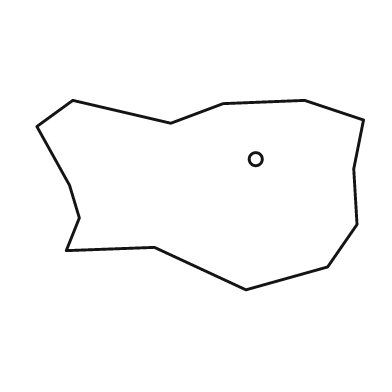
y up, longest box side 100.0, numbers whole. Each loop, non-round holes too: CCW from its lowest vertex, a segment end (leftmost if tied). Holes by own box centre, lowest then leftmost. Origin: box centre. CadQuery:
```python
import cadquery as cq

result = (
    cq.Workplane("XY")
    .moveTo(14.0, -29.0)
    .lineTo(39.0, -22.0)
    .lineTo(48.0, -9.0)
    .lineTo(47.0, 8.0)
    .lineTo(50.0, 23.0)
    .lineTo(32.0, 29.0)
    .lineTo(7.0, 28.0)
    .lineTo(-9.0, 22.0)
    .lineTo(-39.0, 29.0)
    .lineTo(-50.0, 21.0)
    .lineTo(-40.0, 3.0)
    .lineTo(-37.0, -7.0)
    .lineTo(-41.0, -17.0)
    .lineTo(-14.0, -16.0)
    .close()
    .moveTo(17.0, 11.0)
    .circle(2.0)
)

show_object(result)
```